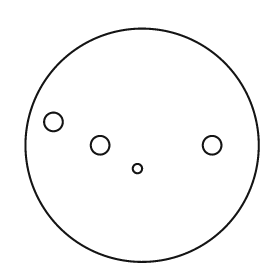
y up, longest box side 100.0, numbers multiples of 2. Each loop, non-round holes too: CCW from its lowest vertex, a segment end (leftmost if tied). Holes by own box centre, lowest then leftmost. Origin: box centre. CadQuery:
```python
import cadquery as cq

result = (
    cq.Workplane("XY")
    .moveTo(0.0, 0.0)
    .circle(50.0)
    .moveTo(-2.0, -10.0)
    .circle(2.0)
    .moveTo(-18.0, 0.0)
    .circle(4.0)
    .moveTo(30.0, 0.0)
    .circle(4.0)
    .moveTo(-38.0, 10.0)
    .circle(4.0)
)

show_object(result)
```